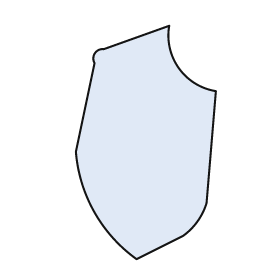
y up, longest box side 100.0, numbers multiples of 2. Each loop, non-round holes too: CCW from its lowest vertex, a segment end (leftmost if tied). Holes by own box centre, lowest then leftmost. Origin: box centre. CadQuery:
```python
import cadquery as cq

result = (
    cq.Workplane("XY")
    .moveTo(-4.0, -50.0)
    .lineTo(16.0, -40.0)
    .threePointArc((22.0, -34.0), (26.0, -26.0))
    .lineTo(30.0, 22.0)
    .threePointArc((14.0, 32.0), (10.0, 50.0))
    .lineTo(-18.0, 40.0)
    .threePointArc((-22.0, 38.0), (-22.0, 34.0))
    .lineTo(-30.0, -4.0)
    .threePointArc((-22.0, -30.0), (-4.0, -50.0))
    .close()
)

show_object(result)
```